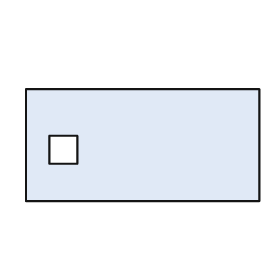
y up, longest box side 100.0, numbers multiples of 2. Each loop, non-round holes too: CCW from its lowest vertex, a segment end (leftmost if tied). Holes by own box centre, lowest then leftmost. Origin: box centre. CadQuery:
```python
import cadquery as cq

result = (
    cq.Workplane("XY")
    .moveTo(-50.0, -24.0)
    .lineTo(50.0, -24.0)
    .lineTo(50.0, 24.0)
    .lineTo(-50.0, 24.0)
    .close()
    .moveTo(-40.0, -8.0)
    .lineTo(-28.0, -8.0)
    .lineTo(-28.0, 4.0)
    .lineTo(-40.0, 4.0)
    .close()
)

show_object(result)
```